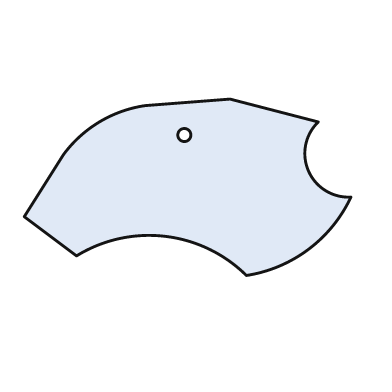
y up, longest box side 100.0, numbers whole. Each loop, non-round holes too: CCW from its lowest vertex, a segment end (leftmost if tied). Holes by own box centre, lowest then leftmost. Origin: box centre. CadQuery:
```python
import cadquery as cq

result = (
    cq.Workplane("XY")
    .moveTo(18.0, -27.0)
    .threePointArc((37.0, -19.0), (50.0, -3.0))
    .threePointArc((37.0, 5.0), (40.0, 20.0))
    .lineTo(13.0, 27.0)
    .lineTo(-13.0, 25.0)
    .threePointArc((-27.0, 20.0), (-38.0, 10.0))
    .lineTo(-50.0, -9.0)
    .lineTo(-34.0, -21.0)
    .threePointArc((-7.0, -15.0), (18.0, -27.0))
    .close()
    .moveTo(-1.0, 16.0)
    .circle(2.0)
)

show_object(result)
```